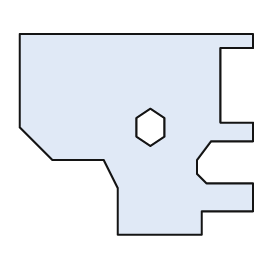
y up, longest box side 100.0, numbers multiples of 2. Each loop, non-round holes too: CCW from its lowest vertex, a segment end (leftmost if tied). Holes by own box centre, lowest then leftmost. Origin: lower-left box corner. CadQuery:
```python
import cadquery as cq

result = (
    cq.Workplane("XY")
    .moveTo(42.0, 0.0)
    .lineTo(78.0, 0.0)
    .lineTo(78.0, 10.0)
    .lineTo(100.0, 10.0)
    .lineTo(100.0, 22.0)
    .lineTo(80.0, 22.0)
    .lineTo(76.0, 26.0)
    .lineTo(76.0, 32.0)
    .lineTo(82.0, 40.0)
    .lineTo(100.0, 40.0)
    .lineTo(100.0, 48.0)
    .lineTo(86.0, 48.0)
    .lineTo(86.0, 80.0)
    .lineTo(100.0, 80.0)
    .lineTo(100.0, 86.0)
    .lineTo(0.0, 86.0)
    .lineTo(0.0, 46.0)
    .lineTo(14.0, 32.0)
    .lineTo(36.0, 32.0)
    .lineTo(42.0, 20.0)
    .close()
    .moveTo(56.0, 38.0)
    .lineTo(62.0, 42.0)
    .lineTo(62.0, 50.0)
    .lineTo(56.0, 54.0)
    .lineTo(50.0, 50.0)
    .lineTo(50.0, 42.0)
    .close()
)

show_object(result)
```